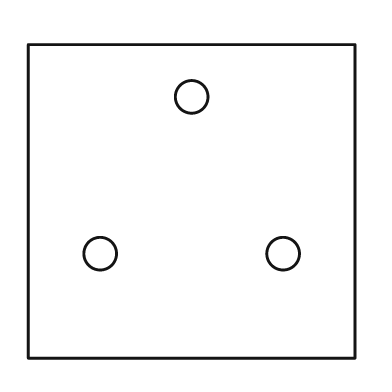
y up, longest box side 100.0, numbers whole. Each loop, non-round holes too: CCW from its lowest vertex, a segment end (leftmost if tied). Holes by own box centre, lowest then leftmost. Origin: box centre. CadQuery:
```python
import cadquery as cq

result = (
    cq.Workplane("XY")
    .moveTo(-50.0, -48.0)
    .lineTo(50.0, -48.0)
    .lineTo(50.0, 48.0)
    .lineTo(-50.0, 48.0)
    .close()
    .moveTo(-28.0, -16.0)
    .circle(5.0)
    .moveTo(28.0, -16.0)
    .circle(5.0)
    .moveTo(0.0, 32.0)
    .circle(5.0)
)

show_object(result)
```